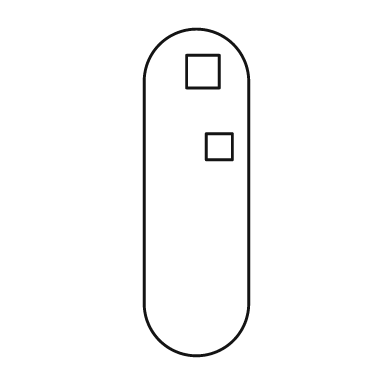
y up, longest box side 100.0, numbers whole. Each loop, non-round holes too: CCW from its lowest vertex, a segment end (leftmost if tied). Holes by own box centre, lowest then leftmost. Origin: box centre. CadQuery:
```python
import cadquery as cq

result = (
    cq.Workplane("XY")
    .moveTo(-16.0, -34.0)
    .threePointArc((0.0, -50.0), (16.0, -34.0))
    .lineTo(16.0, 34.0)
    .threePointArc((0.0, 50.0), (-16.0, 34.0))
    .close()
    .moveTo(3.0, 10.0)
    .lineTo(11.0, 10.0)
    .lineTo(11.0, 18.0)
    .lineTo(3.0, 18.0)
    .close()
    .moveTo(-3.0, 32.0)
    .lineTo(7.0, 32.0)
    .lineTo(7.0, 42.0)
    .lineTo(-3.0, 42.0)
    .close()
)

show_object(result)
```